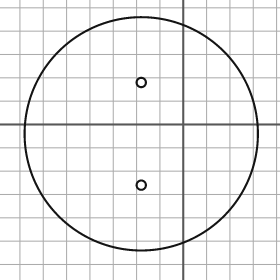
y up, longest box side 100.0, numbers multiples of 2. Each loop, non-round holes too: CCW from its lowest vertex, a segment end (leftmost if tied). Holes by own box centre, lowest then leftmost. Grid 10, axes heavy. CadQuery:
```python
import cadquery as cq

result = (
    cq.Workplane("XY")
    .moveTo(-18.0, -4.0)
    .circle(50.0)
    .moveTo(-18.0, -26.0)
    .circle(2.0)
    .moveTo(-18.0, 18.0)
    .circle(2.0)
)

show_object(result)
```